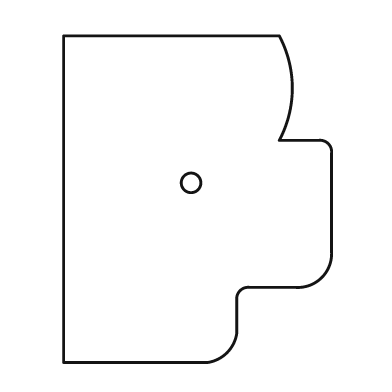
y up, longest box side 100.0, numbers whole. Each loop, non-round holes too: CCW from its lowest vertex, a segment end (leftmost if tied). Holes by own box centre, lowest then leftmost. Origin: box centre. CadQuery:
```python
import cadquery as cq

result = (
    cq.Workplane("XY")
    .moveTo(-41.0, -50.0)
    .lineTo(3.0, -50.0)
    .threePointArc((9.0, -47.0), (12.0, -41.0))
    .lineTo(12.0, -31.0)
    .threePointArc((13.0, -28.0), (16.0, -27.0))
    .lineTo(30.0, -27.0)
    .threePointArc((38.0, -24.0), (41.0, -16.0))
    .lineTo(41.0, 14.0)
    .threePointArc((40.0, 17.0), (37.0, 18.0))
    .lineTo(25.0, 18.0)
    .threePointArc((29.0, 34.0), (25.0, 50.0))
    .lineTo(-41.0, 50.0)
    .close()
    .moveTo(-2.0, 5.0)
    .circle(3.0)
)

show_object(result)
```